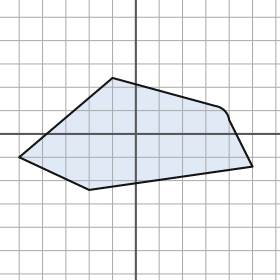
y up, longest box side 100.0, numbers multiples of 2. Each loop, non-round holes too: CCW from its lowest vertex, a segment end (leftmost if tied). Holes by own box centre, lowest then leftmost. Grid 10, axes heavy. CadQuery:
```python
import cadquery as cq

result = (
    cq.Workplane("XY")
    .moveTo(-20.0, -24.0)
    .lineTo(50.0, -14.0)
    .lineTo(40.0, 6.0)
    .threePointArc((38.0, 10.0), (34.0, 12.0))
    .lineTo(-10.0, 24.0)
    .lineTo(-50.0, -10.0)
    .close()
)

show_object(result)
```